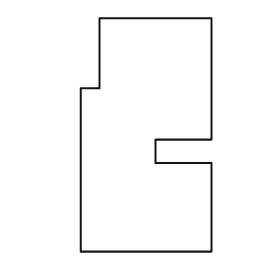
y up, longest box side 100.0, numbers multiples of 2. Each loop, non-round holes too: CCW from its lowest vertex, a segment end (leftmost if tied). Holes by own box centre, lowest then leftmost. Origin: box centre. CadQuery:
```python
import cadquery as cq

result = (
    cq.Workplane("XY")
    .moveTo(-28.0, -50.0)
    .lineTo(28.0, -50.0)
    .lineTo(28.0, -12.0)
    .lineTo(4.0, -12.0)
    .lineTo(4.0, -2.0)
    .lineTo(28.0, -2.0)
    .lineTo(28.0, 50.0)
    .lineTo(-20.0, 50.0)
    .lineTo(-20.0, 20.0)
    .lineTo(-28.0, 20.0)
    .close()
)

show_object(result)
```